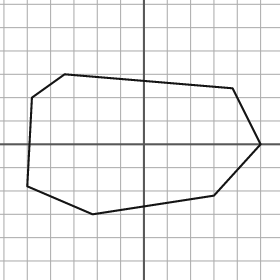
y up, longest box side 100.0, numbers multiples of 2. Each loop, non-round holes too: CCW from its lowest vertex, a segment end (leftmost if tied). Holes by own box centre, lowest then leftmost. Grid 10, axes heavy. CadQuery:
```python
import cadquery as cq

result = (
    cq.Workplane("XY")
    .moveTo(-22.0, -30.0)
    .lineTo(30.0, -22.0)
    .lineTo(50.0, 0.0)
    .lineTo(38.0, 24.0)
    .lineTo(-34.0, 30.0)
    .lineTo(-48.0, 20.0)
    .lineTo(-50.0, -18.0)
    .close()
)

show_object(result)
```